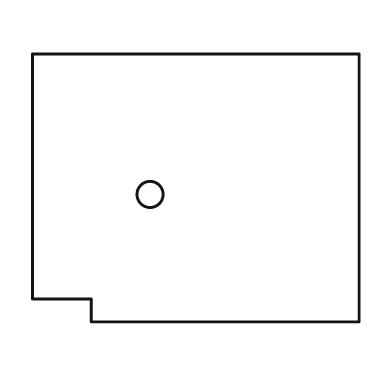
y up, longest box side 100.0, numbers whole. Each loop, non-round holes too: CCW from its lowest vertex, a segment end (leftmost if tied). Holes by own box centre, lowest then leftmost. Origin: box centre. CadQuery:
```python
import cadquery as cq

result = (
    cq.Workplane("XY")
    .moveTo(-32.0, -41.0)
    .lineTo(50.0, -41.0)
    .lineTo(50.0, 41.0)
    .lineTo(-50.0, 41.0)
    .lineTo(-50.0, -34.0)
    .lineTo(-32.0, -34.0)
    .close()
    .moveTo(-14.0, -2.0)
    .circle(4.0)
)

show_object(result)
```